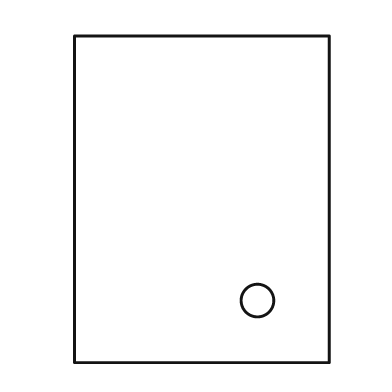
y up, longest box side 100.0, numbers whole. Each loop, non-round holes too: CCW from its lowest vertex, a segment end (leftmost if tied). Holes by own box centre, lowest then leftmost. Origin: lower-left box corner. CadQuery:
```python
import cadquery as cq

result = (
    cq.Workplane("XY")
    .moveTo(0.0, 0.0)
    .lineTo(78.0, 0.0)
    .lineTo(78.0, 100.0)
    .lineTo(0.0, 100.0)
    .close()
    .moveTo(56.0, 19.0)
    .circle(5.0)
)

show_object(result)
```